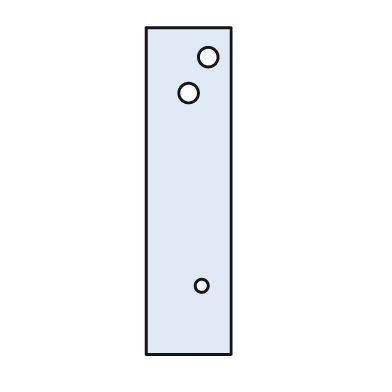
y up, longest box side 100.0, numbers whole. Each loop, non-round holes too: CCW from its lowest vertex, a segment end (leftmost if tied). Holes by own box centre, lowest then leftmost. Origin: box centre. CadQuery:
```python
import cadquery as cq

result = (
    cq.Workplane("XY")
    .moveTo(-13.0, -50.0)
    .lineTo(13.0, -50.0)
    .lineTo(13.0, 50.0)
    .lineTo(-13.0, 50.0)
    .close()
    .moveTo(4.0, -29.0)
    .circle(2.0)
    .moveTo(0.0, 30.0)
    .circle(3.0)
    .moveTo(6.0, 41.0)
    .circle(3.0)
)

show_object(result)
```